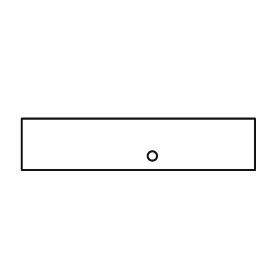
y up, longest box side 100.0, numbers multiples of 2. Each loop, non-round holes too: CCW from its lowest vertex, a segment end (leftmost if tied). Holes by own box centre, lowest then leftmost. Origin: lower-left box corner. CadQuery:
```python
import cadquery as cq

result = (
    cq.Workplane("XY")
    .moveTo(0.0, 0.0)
    .lineTo(100.0, 0.0)
    .lineTo(100.0, 22.0)
    .lineTo(0.0, 22.0)
    .close()
    .moveTo(56.0, 6.0)
    .circle(2.0)
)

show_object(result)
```